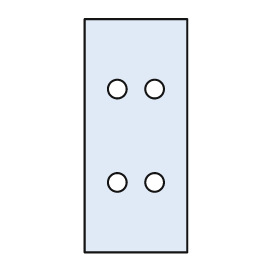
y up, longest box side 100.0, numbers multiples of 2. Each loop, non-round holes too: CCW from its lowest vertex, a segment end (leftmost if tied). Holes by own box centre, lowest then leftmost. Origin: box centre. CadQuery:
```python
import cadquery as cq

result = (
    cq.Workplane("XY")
    .moveTo(-22.0, -50.0)
    .lineTo(22.0, -50.0)
    .lineTo(22.0, 50.0)
    .lineTo(-22.0, 50.0)
    .close()
    .moveTo(-8.0, -20.0)
    .circle(4.0)
    .moveTo(8.0, -20.0)
    .circle(4.0)
    .moveTo(-8.0, 20.0)
    .circle(4.0)
    .moveTo(8.0, 20.0)
    .circle(4.0)
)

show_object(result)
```